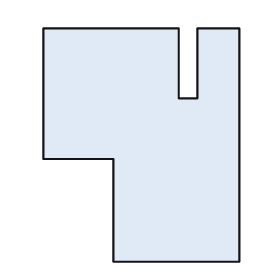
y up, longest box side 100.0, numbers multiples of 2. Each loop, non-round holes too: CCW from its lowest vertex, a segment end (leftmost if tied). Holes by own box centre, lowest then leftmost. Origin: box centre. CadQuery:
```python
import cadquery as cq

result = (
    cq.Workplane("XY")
    .moveTo(-12.0, -50.0)
    .lineTo(42.0, -50.0)
    .lineTo(42.0, 50.0)
    .lineTo(24.0, 50.0)
    .lineTo(24.0, 20.0)
    .lineTo(16.0, 20.0)
    .lineTo(16.0, 50.0)
    .lineTo(-42.0, 50.0)
    .lineTo(-42.0, -6.0)
    .lineTo(-12.0, -6.0)
    .close()
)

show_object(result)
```